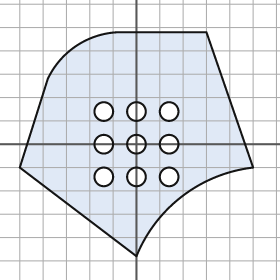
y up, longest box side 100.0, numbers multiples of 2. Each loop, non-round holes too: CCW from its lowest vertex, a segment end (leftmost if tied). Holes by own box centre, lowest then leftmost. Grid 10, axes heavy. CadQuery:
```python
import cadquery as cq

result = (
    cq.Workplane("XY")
    .moveTo(0.0, -48.0)
    .threePointArc((20.0, -22.0), (50.0, -10.0))
    .lineTo(30.0, 48.0)
    .lineTo(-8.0, 48.0)
    .threePointArc((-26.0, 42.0), (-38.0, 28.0))
    .lineTo(-50.0, -10.0)
    .close()
    .moveTo(-14.0, -14.0)
    .circle(4.0)
    .moveTo(0.0, -14.0)
    .circle(4.0)
    .moveTo(14.0, -14.0)
    .circle(4.0)
    .moveTo(-14.0, 0.0)
    .circle(4.0)
    .moveTo(0.0, 0.0)
    .circle(4.0)
    .moveTo(14.0, 0.0)
    .circle(4.0)
    .moveTo(-14.0, 14.0)
    .circle(4.0)
    .moveTo(0.0, 14.0)
    .circle(4.0)
    .moveTo(14.0, 14.0)
    .circle(4.0)
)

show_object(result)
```